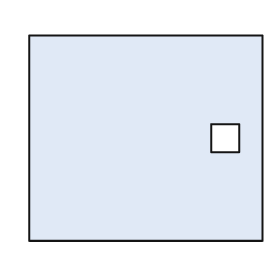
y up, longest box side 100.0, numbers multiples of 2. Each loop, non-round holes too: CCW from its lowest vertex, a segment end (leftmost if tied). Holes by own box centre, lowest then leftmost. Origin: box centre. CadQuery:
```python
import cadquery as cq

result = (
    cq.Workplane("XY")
    .moveTo(-50.0, -44.0)
    .lineTo(50.0, -44.0)
    .lineTo(50.0, 44.0)
    .lineTo(-50.0, 44.0)
    .close()
    .moveTo(28.0, -6.0)
    .lineTo(40.0, -6.0)
    .lineTo(40.0, 6.0)
    .lineTo(28.0, 6.0)
    .close()
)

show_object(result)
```